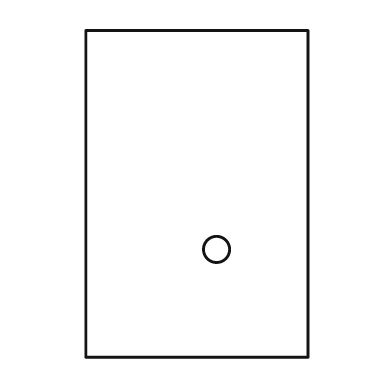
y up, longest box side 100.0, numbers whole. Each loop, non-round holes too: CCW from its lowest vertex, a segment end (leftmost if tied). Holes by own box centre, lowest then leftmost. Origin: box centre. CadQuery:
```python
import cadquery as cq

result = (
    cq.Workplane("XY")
    .moveTo(-34.0, -50.0)
    .lineTo(34.0, -50.0)
    .lineTo(34.0, 50.0)
    .lineTo(-34.0, 50.0)
    .close()
    .moveTo(6.0, -17.0)
    .circle(4.0)
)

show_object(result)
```